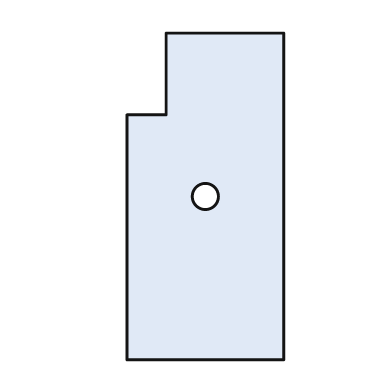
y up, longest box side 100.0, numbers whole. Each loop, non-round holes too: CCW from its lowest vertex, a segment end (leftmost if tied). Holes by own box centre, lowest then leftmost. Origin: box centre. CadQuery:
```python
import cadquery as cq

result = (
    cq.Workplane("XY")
    .moveTo(-24.0, -50.0)
    .lineTo(24.0, -50.0)
    .lineTo(24.0, 50.0)
    .lineTo(-12.0, 50.0)
    .lineTo(-12.0, 25.0)
    .lineTo(-24.0, 25.0)
    .close()
    .moveTo(0.0, 0.0)
    .circle(4.0)
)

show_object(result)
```